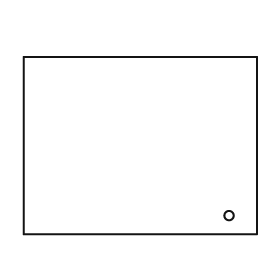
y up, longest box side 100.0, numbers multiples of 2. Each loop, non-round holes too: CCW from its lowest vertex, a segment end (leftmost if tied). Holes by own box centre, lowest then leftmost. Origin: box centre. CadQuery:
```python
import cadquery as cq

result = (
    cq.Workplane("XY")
    .moveTo(-50.0, -38.0)
    .lineTo(50.0, -38.0)
    .lineTo(50.0, 38.0)
    .lineTo(-50.0, 38.0)
    .close()
    .moveTo(38.0, -30.0)
    .circle(2.0)
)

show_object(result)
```